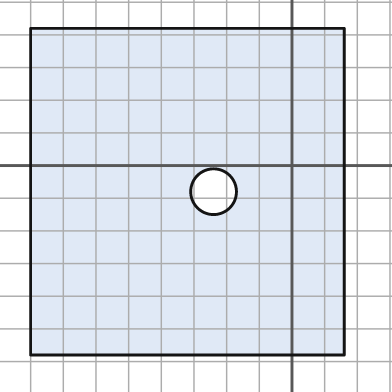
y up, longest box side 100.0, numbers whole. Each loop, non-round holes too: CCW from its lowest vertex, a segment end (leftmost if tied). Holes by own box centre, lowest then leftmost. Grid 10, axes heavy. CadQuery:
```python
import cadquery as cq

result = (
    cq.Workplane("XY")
    .moveTo(-80.0, -58.0)
    .lineTo(16.0, -58.0)
    .lineTo(16.0, 42.0)
    .lineTo(-80.0, 42.0)
    .close()
    .moveTo(-24.0, -8.0)
    .circle(7.0)
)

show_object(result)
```